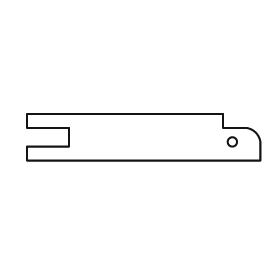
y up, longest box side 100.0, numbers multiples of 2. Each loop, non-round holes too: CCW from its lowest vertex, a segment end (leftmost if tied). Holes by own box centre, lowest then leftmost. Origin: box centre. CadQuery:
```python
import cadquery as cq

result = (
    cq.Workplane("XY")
    .moveTo(-50.0, -10.0)
    .lineTo(50.0, -10.0)
    .lineTo(50.0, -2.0)
    .threePointArc((48.0, 2.0), (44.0, 4.0))
    .lineTo(34.0, 4.0)
    .lineTo(34.0, 10.0)
    .lineTo(-50.0, 10.0)
    .lineTo(-50.0, 4.0)
    .lineTo(-32.0, 4.0)
    .lineTo(-32.0, -4.0)
    .lineTo(-50.0, -4.0)
    .close()
    .moveTo(38.0, -2.0)
    .circle(2.0)
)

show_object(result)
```